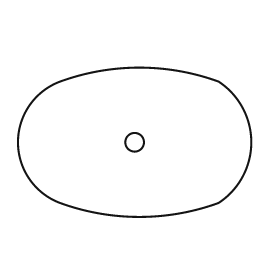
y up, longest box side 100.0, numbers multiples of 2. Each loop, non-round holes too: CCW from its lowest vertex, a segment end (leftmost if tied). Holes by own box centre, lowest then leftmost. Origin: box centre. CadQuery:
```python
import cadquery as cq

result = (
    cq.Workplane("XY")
    .moveTo(-32.0, -26.0)
    .threePointArc((2.0, -32.0), (36.0, -26.0))
    .threePointArc((50.0, 0.0), (36.0, 26.0))
    .threePointArc((2.0, 32.0), (-32.0, 26.0))
    .threePointArc((-50.0, 0.0), (-32.0, -26.0))
    .close()
    .moveTo(0.0, 0.0)
    .circle(4.0)
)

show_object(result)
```